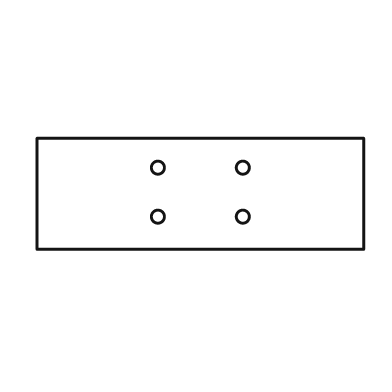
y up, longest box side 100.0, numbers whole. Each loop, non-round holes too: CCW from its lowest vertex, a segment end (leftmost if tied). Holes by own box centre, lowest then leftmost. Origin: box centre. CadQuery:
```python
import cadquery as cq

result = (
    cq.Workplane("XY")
    .moveTo(-50.0, -17.0)
    .lineTo(50.0, -17.0)
    .lineTo(50.0, 17.0)
    .lineTo(-50.0, 17.0)
    .close()
    .moveTo(-13.0, -7.0)
    .circle(2.0)
    .moveTo(13.0, -7.0)
    .circle(2.0)
    .moveTo(-13.0, 8.0)
    .circle(2.0)
    .moveTo(13.0, 8.0)
    .circle(2.0)
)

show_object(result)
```